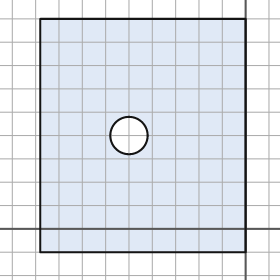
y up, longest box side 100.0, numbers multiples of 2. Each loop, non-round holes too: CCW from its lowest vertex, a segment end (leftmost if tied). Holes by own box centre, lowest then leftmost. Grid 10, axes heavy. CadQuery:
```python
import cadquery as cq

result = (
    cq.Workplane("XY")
    .moveTo(-88.0, -10.0)
    .lineTo(0.0, -10.0)
    .lineTo(0.0, 90.0)
    .lineTo(-88.0, 90.0)
    .close()
    .moveTo(-50.0, 40.0)
    .circle(8.0)
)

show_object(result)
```